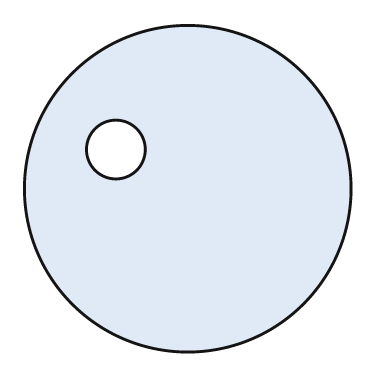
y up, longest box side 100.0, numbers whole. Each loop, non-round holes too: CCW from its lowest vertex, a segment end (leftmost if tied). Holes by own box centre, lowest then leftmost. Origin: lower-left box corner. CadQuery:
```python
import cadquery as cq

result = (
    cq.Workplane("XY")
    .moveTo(50.0, 50.0)
    .circle(50.0)
    .moveTo(28.0, 62.0)
    .circle(9.0)
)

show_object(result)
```